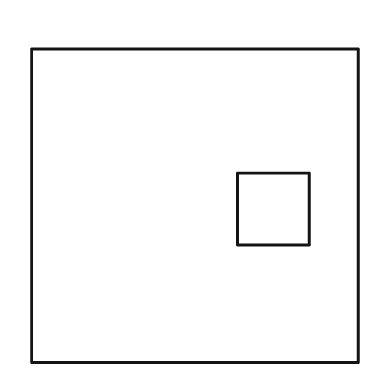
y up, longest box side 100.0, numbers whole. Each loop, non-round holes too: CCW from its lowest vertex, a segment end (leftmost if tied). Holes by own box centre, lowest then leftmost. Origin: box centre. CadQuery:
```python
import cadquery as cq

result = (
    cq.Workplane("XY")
    .moveTo(-50.0, -48.0)
    .lineTo(50.0, -48.0)
    .lineTo(50.0, 48.0)
    .lineTo(-50.0, 48.0)
    .close()
    .moveTo(13.0, -12.0)
    .lineTo(35.0, -12.0)
    .lineTo(35.0, 10.0)
    .lineTo(13.0, 10.0)
    .close()
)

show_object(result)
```